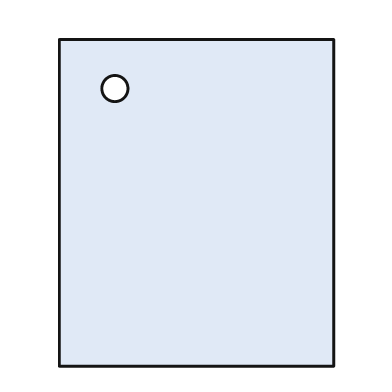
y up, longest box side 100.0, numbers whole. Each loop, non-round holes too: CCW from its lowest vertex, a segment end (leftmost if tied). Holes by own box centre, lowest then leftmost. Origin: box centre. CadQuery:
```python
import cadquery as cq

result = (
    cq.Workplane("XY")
    .moveTo(-42.0, -50.0)
    .lineTo(42.0, -50.0)
    .lineTo(42.0, 50.0)
    .lineTo(-42.0, 50.0)
    .close()
    .moveTo(-25.0, 35.0)
    .circle(4.0)
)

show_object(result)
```